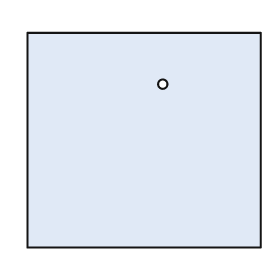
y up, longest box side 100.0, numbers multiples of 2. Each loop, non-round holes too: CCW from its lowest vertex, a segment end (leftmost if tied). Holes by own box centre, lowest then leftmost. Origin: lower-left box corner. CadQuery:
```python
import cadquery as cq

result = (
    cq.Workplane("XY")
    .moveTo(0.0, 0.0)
    .lineTo(100.0, 0.0)
    .lineTo(100.0, 92.0)
    .lineTo(0.0, 92.0)
    .close()
    .moveTo(58.0, 70.0)
    .circle(2.0)
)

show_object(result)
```